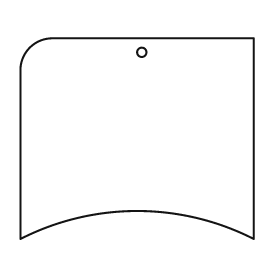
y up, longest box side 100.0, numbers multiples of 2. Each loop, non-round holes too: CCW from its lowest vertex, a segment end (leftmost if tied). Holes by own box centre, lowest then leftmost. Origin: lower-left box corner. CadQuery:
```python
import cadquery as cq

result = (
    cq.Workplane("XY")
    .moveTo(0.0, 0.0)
    .threePointArc((50.0, 12.0), (100.0, 0.0))
    .lineTo(100.0, 86.0)
    .lineTo(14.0, 86.0)
    .threePointArc((4.0, 82.0), (0.0, 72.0))
    .close()
    .moveTo(52.0, 80.0)
    .circle(2.0)
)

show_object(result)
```